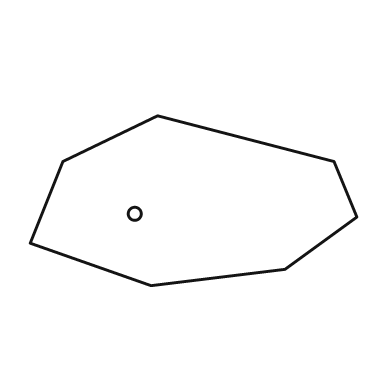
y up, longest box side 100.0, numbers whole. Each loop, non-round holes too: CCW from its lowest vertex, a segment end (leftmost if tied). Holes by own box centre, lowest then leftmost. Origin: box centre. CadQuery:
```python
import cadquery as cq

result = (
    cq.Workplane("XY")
    .moveTo(-13.0, -26.0)
    .lineTo(28.0, -21.0)
    .lineTo(50.0, -5.0)
    .lineTo(43.0, 12.0)
    .lineTo(-11.0, 26.0)
    .lineTo(-40.0, 12.0)
    .lineTo(-50.0, -13.0)
    .close()
    .moveTo(-18.0, -4.0)
    .circle(2.0)
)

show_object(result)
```